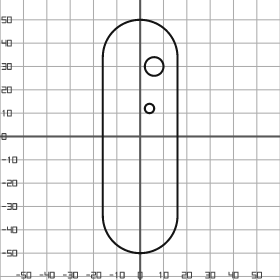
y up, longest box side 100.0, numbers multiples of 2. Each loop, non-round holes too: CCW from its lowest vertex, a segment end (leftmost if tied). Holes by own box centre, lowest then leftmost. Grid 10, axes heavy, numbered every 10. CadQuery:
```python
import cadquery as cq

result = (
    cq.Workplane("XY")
    .moveTo(-16.0, -34.0)
    .threePointArc((0.0, -50.0), (16.0, -34.0))
    .lineTo(16.0, 34.0)
    .threePointArc((0.0, 50.0), (-16.0, 34.0))
    .close()
    .moveTo(4.0, 12.0)
    .circle(2.0)
    .moveTo(6.0, 30.0)
    .circle(4.0)
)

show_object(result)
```